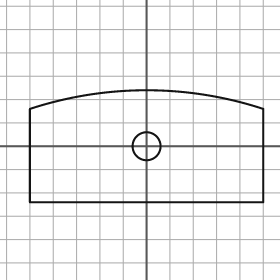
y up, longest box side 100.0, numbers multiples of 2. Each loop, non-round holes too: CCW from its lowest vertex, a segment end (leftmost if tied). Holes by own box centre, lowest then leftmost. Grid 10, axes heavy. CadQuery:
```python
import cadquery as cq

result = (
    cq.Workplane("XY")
    .moveTo(-50.0, -24.0)
    .lineTo(50.0, -24.0)
    .lineTo(50.0, 16.0)
    .threePointArc((0.0, 24.0), (-50.0, 16.0))
    .close()
    .moveTo(0.0, 0.0)
    .circle(6.0)
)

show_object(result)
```